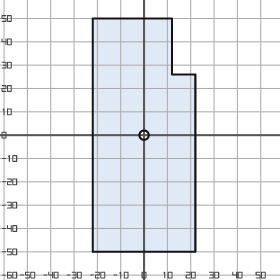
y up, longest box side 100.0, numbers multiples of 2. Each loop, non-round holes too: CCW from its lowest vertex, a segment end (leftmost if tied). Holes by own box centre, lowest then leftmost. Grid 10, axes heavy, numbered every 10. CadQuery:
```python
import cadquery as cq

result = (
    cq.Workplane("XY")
    .moveTo(-22.0, -50.0)
    .lineTo(22.0, -50.0)
    .lineTo(22.0, 26.0)
    .lineTo(12.0, 26.0)
    .lineTo(12.0, 50.0)
    .lineTo(-22.0, 50.0)
    .close()
    .moveTo(0.0, 0.0)
    .circle(2.0)
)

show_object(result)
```